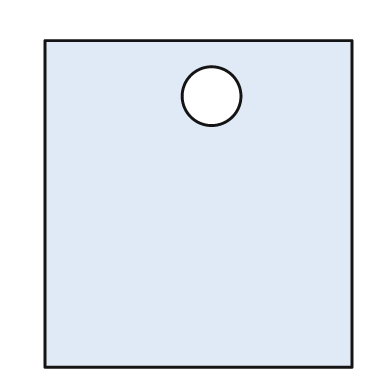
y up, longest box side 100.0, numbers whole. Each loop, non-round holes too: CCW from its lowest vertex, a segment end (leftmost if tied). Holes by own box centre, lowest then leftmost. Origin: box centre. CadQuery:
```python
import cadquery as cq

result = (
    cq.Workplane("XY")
    .moveTo(-47.0, -50.0)
    .lineTo(47.0, -50.0)
    .lineTo(47.0, 50.0)
    .lineTo(-47.0, 50.0)
    .close()
    .moveTo(4.0, 33.0)
    .circle(9.0)
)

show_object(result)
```